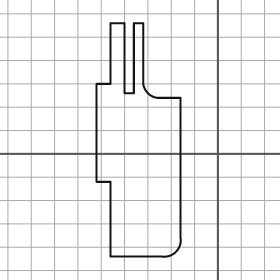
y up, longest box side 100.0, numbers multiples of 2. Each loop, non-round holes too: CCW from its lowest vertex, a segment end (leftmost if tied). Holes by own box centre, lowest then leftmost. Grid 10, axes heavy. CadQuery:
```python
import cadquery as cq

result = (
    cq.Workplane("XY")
    .moveTo(-46.0, -44.0)
    .lineTo(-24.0, -44.0)
    .threePointArc((-18.0, -42.0), (-16.0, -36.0))
    .lineTo(-16.0, 24.0)
    .lineTo(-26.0, 24.0)
    .threePointArc((-30.0, 26.0), (-32.0, 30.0))
    .lineTo(-32.0, 56.0)
    .lineTo(-36.0, 56.0)
    .lineTo(-36.0, 26.0)
    .lineTo(-40.0, 26.0)
    .lineTo(-40.0, 56.0)
    .lineTo(-46.0, 56.0)
    .lineTo(-46.0, 30.0)
    .lineTo(-52.0, 30.0)
    .lineTo(-52.0, -12.0)
    .lineTo(-46.0, -12.0)
    .close()
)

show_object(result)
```